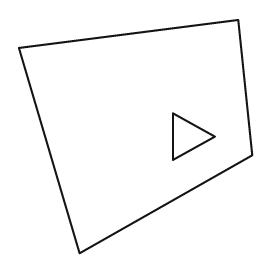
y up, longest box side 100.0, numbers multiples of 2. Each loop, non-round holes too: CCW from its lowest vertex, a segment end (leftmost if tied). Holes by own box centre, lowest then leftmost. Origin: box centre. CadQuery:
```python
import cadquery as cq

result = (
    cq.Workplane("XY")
    .moveTo(-24.0, -50.0)
    .lineTo(50.0, -8.0)
    .lineTo(44.0, 50.0)
    .lineTo(-50.0, 38.0)
    .close()
    .moveTo(16.0, -10.0)
    .lineTo(34.0, 0.0)
    .lineTo(16.0, 10.0)
    .close()
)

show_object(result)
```